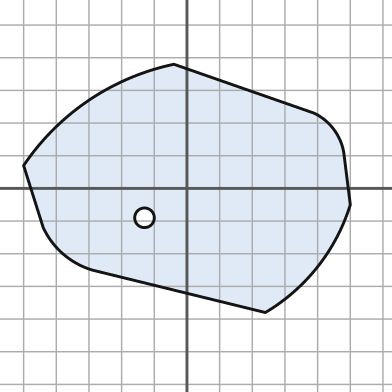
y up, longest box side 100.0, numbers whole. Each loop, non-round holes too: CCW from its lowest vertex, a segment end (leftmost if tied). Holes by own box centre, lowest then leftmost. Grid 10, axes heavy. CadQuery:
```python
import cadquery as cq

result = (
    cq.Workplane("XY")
    .moveTo(24.0, -38.0)
    .threePointArc((40.0, -24.0), (50.0, -5.0))
    .lineTo(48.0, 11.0)
    .threePointArc((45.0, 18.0), (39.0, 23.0))
    .lineTo(-4.0, 38.0)
    .threePointArc((-30.0, 27.0), (-50.0, 7.0))
    .lineTo(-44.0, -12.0)
    .threePointArc((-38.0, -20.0), (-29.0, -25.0))
    .close()
    .moveTo(-13.0, -9.0)
    .circle(3.0)
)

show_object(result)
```